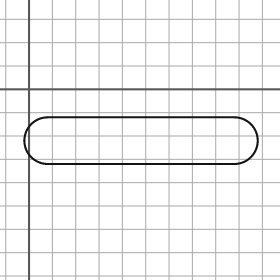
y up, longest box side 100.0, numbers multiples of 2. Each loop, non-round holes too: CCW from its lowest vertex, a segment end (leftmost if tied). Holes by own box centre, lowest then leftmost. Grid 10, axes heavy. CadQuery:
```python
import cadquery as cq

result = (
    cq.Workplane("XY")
    .moveTo(8.0, -32.0)
    .lineTo(88.0, -32.0)
    .threePointArc((98.0, -22.0), (88.0, -12.0))
    .lineTo(8.0, -12.0)
    .threePointArc((-2.0, -22.0), (8.0, -32.0))
    .close()
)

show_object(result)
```